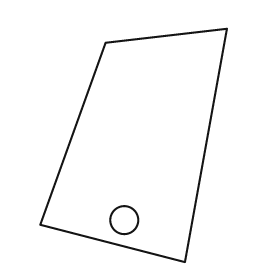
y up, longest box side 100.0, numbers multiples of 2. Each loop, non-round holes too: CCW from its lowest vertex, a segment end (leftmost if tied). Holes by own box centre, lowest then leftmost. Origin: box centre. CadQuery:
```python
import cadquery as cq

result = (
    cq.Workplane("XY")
    .moveTo(22.0, -50.0)
    .lineTo(40.0, 50.0)
    .lineTo(-12.0, 44.0)
    .lineTo(-40.0, -34.0)
    .close()
    .moveTo(-4.0, -32.0)
    .circle(6.0)
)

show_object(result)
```